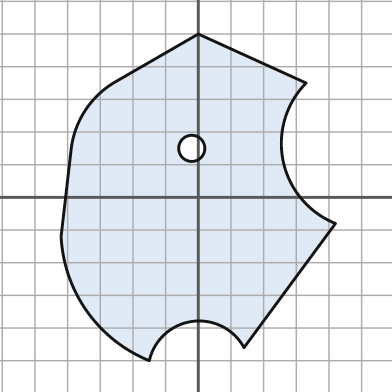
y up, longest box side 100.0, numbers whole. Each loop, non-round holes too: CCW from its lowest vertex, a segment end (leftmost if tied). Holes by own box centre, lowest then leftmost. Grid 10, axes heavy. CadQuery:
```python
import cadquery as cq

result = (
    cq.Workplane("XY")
    .moveTo(-15.0, -50.0)
    .threePointArc((-2.0, -38.0), (14.0, -46.0))
    .lineTo(42.0, -8.0)
    .threePointArc((26.0, 11.0), (33.0, 35.0))
    .lineTo(0.0, 50.0)
    .lineTo(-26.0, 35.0)
    .threePointArc((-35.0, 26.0), (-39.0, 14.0))
    .lineTo(-42.0, -12.0)
    .threePointArc((-34.0, -35.0), (-15.0, -50.0))
    .close()
    .moveTo(-2.0, 15.0)
    .circle(4.0)
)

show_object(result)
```